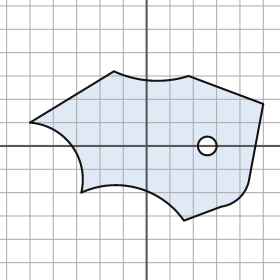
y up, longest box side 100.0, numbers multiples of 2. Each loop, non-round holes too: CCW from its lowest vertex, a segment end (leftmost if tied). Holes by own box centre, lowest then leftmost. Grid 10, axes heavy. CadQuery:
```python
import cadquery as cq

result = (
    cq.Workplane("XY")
    .moveTo(16.0, -32.0)
    .lineTo(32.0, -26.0)
    .threePointArc((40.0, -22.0), (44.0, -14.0))
    .lineTo(50.0, 18.0)
    .lineTo(18.0, 30.0)
    .threePointArc((2.0, 28.0), (-14.0, 32.0))
    .lineTo(-50.0, 10.0)
    .threePointArc((-32.0, 0.0), (-28.0, -20.0))
    .threePointArc((-4.0, -18.0), (16.0, -32.0))
    .close()
    .moveTo(26.0, 0.0)
    .circle(4.0)
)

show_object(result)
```